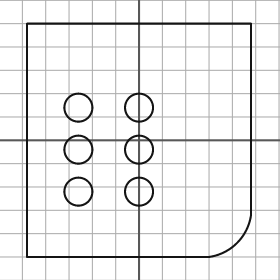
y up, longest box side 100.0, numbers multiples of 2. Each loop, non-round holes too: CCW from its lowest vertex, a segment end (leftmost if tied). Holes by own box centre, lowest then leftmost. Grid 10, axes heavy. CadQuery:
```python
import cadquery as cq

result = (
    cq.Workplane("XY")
    .moveTo(-48.0, -50.0)
    .lineTo(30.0, -50.0)
    .threePointArc((42.0, -44.0), (48.0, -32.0))
    .lineTo(48.0, 50.0)
    .lineTo(-48.0, 50.0)
    .close()
    .moveTo(-26.0, -22.0)
    .circle(6.0)
    .moveTo(0.0, -22.0)
    .circle(6.0)
    .moveTo(-26.0, -4.0)
    .circle(6.0)
    .moveTo(0.0, -4.0)
    .circle(6.0)
    .moveTo(-26.0, 14.0)
    .circle(6.0)
    .moveTo(0.0, 14.0)
    .circle(6.0)
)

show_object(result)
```